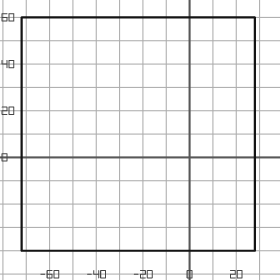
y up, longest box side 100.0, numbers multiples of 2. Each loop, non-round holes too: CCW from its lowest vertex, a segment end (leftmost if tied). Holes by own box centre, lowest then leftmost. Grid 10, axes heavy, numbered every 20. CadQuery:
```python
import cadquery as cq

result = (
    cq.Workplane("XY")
    .moveTo(-72.0, -40.0)
    .lineTo(28.0, -40.0)
    .lineTo(28.0, 60.0)
    .lineTo(-72.0, 60.0)
    .close()
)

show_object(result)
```